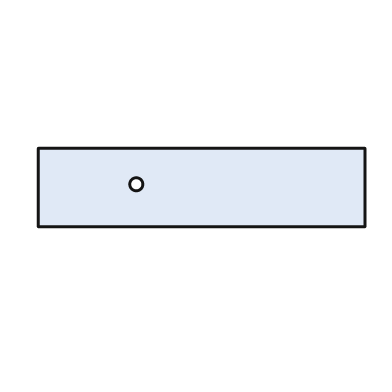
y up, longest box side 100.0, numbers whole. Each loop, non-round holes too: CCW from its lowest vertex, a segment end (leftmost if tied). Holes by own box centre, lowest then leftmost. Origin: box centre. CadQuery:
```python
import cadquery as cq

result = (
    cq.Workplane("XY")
    .moveTo(-50.0, -12.0)
    .lineTo(50.0, -12.0)
    .lineTo(50.0, 12.0)
    .lineTo(-50.0, 12.0)
    .close()
    .moveTo(-20.0, 1.0)
    .circle(2.0)
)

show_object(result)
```